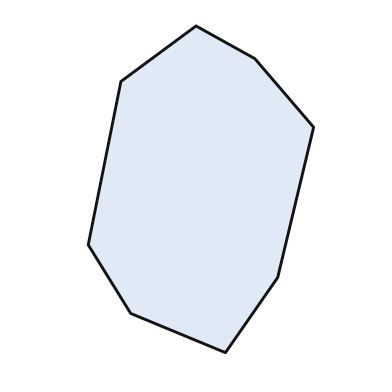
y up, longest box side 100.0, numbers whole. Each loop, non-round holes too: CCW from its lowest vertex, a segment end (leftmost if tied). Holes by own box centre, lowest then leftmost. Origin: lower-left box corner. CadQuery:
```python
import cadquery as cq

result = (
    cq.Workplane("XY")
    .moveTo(42.0, 0.0)
    .lineTo(58.0, 23.0)
    .lineTo(69.0, 69.0)
    .lineTo(51.0, 90.0)
    .lineTo(33.0, 100.0)
    .lineTo(10.0, 83.0)
    .lineTo(0.0, 33.0)
    .lineTo(13.0, 12.0)
    .close()
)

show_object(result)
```